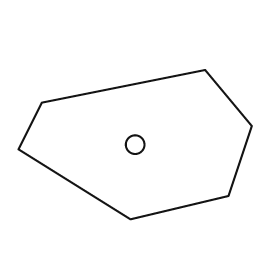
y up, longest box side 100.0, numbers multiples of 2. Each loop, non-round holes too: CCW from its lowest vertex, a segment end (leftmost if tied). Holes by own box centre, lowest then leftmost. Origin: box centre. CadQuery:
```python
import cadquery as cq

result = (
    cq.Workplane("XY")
    .moveTo(-2.0, -32.0)
    .lineTo(40.0, -22.0)
    .lineTo(50.0, 8.0)
    .lineTo(30.0, 32.0)
    .lineTo(-40.0, 18.0)
    .lineTo(-50.0, -2.0)
    .close()
    .moveTo(0.0, 0.0)
    .circle(4.0)
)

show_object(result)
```